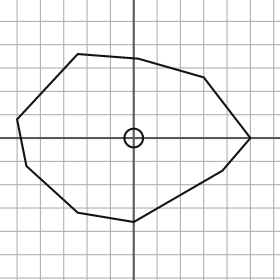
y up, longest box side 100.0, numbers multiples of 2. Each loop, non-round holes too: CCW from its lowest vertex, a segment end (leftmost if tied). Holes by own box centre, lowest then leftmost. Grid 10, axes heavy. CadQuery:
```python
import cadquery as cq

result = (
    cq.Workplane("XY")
    .moveTo(0.0, -36.0)
    .lineTo(38.0, -14.0)
    .lineTo(50.0, 0.0)
    .lineTo(30.0, 26.0)
    .lineTo(2.0, 34.0)
    .lineTo(-24.0, 36.0)
    .lineTo(-50.0, 8.0)
    .lineTo(-46.0, -12.0)
    .lineTo(-24.0, -32.0)
    .close()
    .moveTo(0.0, 0.0)
    .circle(4.0)
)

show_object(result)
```